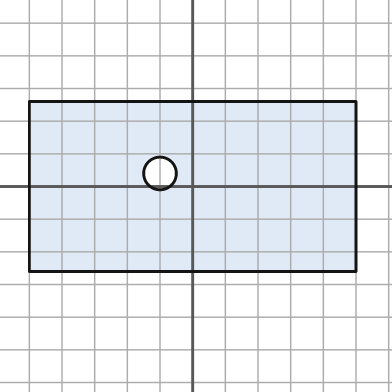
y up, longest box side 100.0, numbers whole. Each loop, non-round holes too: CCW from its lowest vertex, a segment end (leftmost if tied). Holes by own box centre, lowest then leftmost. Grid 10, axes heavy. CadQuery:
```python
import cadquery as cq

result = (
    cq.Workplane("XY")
    .moveTo(-50.0, -26.0)
    .lineTo(50.0, -26.0)
    .lineTo(50.0, 26.0)
    .lineTo(-50.0, 26.0)
    .close()
    .moveTo(-10.0, 4.0)
    .circle(5.0)
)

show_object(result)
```